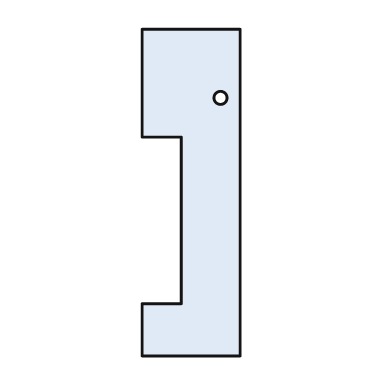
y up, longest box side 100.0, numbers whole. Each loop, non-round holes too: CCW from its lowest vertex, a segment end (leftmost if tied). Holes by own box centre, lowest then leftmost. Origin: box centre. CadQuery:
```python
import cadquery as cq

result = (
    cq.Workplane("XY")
    .moveTo(-15.0, -50.0)
    .lineTo(15.0, -50.0)
    .lineTo(15.0, 50.0)
    .lineTo(-15.0, 50.0)
    .lineTo(-15.0, 17.0)
    .lineTo(-3.0, 17.0)
    .lineTo(-3.0, -34.0)
    .lineTo(-15.0, -34.0)
    .close()
    .moveTo(9.0, 29.0)
    .circle(2.0)
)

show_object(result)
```